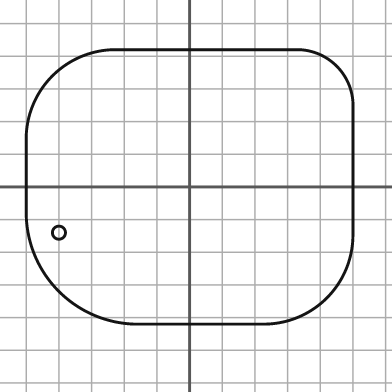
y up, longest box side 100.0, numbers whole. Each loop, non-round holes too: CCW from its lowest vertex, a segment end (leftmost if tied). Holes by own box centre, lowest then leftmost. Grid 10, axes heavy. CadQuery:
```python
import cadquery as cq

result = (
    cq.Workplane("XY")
    .moveTo(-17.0, -42.0)
    .lineTo(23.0, -42.0)
    .threePointArc((42.0, -34.0), (50.0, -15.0))
    .lineTo(50.0, 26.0)
    .threePointArc((45.0, 37.0), (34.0, 42.0))
    .lineTo(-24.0, 42.0)
    .threePointArc((-42.0, 34.0), (-50.0, 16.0))
    .lineTo(-50.0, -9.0)
    .threePointArc((-40.0, -32.0), (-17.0, -42.0))
    .close()
    .moveTo(-40.0, -14.0)
    .circle(2.0)
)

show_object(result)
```